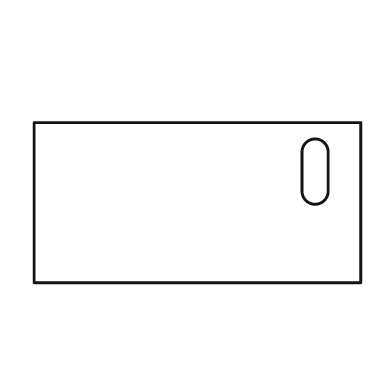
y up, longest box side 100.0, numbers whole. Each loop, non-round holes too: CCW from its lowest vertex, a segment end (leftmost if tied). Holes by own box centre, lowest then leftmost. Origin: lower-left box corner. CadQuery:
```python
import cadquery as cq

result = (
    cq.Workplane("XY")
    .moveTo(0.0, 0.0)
    .lineTo(100.0, 0.0)
    .lineTo(100.0, 49.0)
    .lineTo(0.0, 49.0)
    .close()
    .moveTo(82.0, 28.0)
    .threePointArc((86.0, 24.0), (90.0, 28.0))
    .lineTo(90.0, 40.0)
    .threePointArc((86.0, 44.0), (82.0, 40.0))
    .close()
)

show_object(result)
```